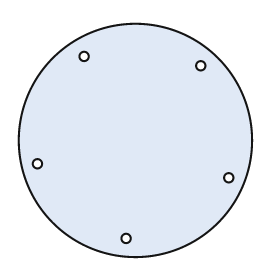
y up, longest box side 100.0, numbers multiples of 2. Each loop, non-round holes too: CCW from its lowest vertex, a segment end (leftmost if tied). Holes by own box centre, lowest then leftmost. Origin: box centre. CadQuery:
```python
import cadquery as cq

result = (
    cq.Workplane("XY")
    .moveTo(0.0, 0.0)
    .circle(50.0)
    .moveTo(-4.0, -42.0)
    .circle(2.0)
    .moveTo(40.0, -16.0)
    .circle(2.0)
    .moveTo(-42.0, -10.0)
    .circle(2.0)
    .moveTo(28.0, 32.0)
    .circle(2.0)
    .moveTo(-22.0, 36.0)
    .circle(2.0)
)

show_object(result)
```